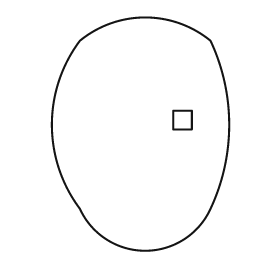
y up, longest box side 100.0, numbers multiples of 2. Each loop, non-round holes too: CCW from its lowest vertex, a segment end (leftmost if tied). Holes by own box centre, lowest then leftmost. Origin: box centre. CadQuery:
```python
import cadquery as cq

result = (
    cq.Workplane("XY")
    .moveTo(-26.0, -32.0)
    .threePointArc((2.0, -50.0), (30.0, -32.0))
    .threePointArc((38.0, 4.0), (30.0, 40.0))
    .threePointArc((2.0, 50.0), (-26.0, 40.0))
    .threePointArc((-38.0, 4.0), (-26.0, -32.0))
    .close()
    .moveTo(14.0, 2.0)
    .lineTo(22.0, 2.0)
    .lineTo(22.0, 10.0)
    .lineTo(14.0, 10.0)
    .close()
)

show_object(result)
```